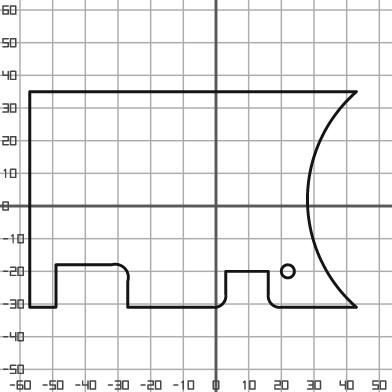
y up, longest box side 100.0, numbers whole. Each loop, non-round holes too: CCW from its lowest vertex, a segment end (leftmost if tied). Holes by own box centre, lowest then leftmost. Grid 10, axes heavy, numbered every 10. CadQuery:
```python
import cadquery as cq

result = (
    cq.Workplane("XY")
    .moveTo(-57.0, -31.0)
    .lineTo(-49.0, -31.0)
    .lineTo(-49.0, -18.0)
    .lineTo(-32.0, -18.0)
    .threePointArc((-28.0, -19.0), (-27.0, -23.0))
    .lineTo(-27.0, -31.0)
    .lineTo(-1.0, -31.0)
    .threePointArc((2.0, -30.0), (3.0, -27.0))
    .lineTo(3.0, -20.0)
    .lineTo(16.0, -20.0)
    .lineTo(16.0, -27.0)
    .threePointArc((17.0, -30.0), (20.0, -31.0))
    .lineTo(43.0, -31.0)
    .threePointArc((28.0, 2.0), (43.0, 35.0))
    .lineTo(-57.0, 35.0)
    .close()
    .moveTo(22.0, -20.0)
    .circle(2.0)
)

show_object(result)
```